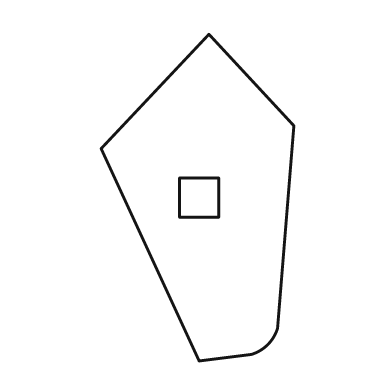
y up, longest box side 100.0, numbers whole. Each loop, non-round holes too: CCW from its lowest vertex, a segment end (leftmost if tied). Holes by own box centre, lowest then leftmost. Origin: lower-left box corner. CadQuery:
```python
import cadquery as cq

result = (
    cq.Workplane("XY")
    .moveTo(30.0, 0.0)
    .lineTo(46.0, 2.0)
    .threePointArc((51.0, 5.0), (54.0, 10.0))
    .lineTo(59.0, 72.0)
    .lineTo(33.0, 100.0)
    .lineTo(0.0, 65.0)
    .close()
    .moveTo(24.0, 44.0)
    .lineTo(36.0, 44.0)
    .lineTo(36.0, 56.0)
    .lineTo(24.0, 56.0)
    .close()
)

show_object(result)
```